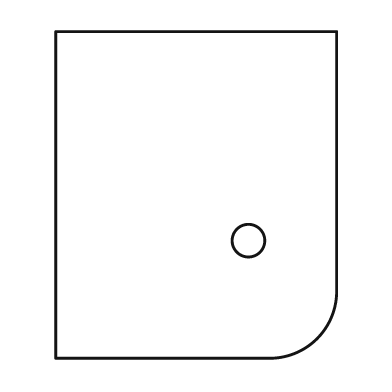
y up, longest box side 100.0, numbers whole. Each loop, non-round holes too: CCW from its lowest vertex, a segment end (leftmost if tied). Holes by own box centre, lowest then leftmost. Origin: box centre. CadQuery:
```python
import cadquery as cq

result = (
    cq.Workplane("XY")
    .moveTo(-43.0, -50.0)
    .lineTo(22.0, -50.0)
    .threePointArc((37.0, -44.0), (43.0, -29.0))
    .lineTo(43.0, 50.0)
    .lineTo(-43.0, 50.0)
    .close()
    .moveTo(16.0, -14.0)
    .circle(5.0)
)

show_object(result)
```